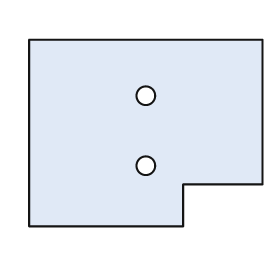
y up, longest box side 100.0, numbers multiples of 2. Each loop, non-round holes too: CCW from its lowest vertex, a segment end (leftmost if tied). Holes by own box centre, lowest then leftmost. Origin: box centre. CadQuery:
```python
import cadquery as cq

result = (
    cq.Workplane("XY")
    .moveTo(-50.0, -40.0)
    .lineTo(16.0, -40.0)
    .lineTo(16.0, -22.0)
    .lineTo(50.0, -22.0)
    .lineTo(50.0, 40.0)
    .lineTo(-50.0, 40.0)
    .close()
    .moveTo(0.0, -14.0)
    .circle(4.0)
    .moveTo(0.0, 16.0)
    .circle(4.0)
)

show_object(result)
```